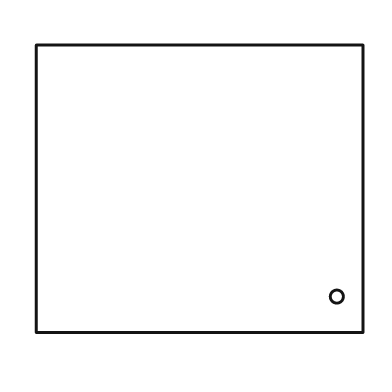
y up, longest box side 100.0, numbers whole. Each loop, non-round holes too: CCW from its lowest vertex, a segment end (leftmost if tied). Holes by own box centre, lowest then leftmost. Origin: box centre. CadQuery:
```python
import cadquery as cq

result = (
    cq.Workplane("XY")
    .moveTo(-50.0, -44.0)
    .lineTo(50.0, -44.0)
    .lineTo(50.0, 44.0)
    .lineTo(-50.0, 44.0)
    .close()
    .moveTo(42.0, -33.0)
    .circle(2.0)
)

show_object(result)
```